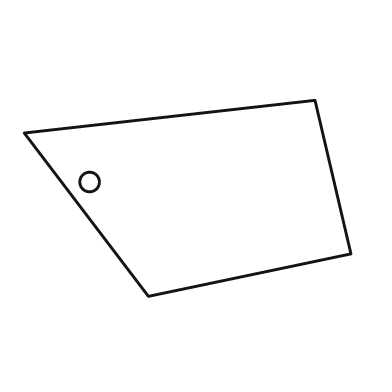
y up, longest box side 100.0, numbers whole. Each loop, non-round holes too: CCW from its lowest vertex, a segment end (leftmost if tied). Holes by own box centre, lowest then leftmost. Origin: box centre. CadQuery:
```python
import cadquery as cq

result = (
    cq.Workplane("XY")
    .moveTo(-12.0, -30.0)
    .lineTo(50.0, -17.0)
    .lineTo(39.0, 30.0)
    .lineTo(-50.0, 20.0)
    .close()
    .moveTo(-30.0, 5.0)
    .circle(3.0)
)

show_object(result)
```